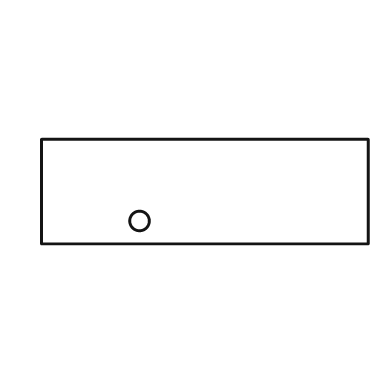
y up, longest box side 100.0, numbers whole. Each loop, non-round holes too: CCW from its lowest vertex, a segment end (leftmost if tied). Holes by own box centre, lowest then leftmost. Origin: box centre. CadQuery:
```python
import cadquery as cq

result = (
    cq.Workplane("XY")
    .moveTo(-50.0, -16.0)
    .lineTo(50.0, -16.0)
    .lineTo(50.0, 16.0)
    .lineTo(-50.0, 16.0)
    .close()
    .moveTo(-20.0, -9.0)
    .circle(3.0)
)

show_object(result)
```